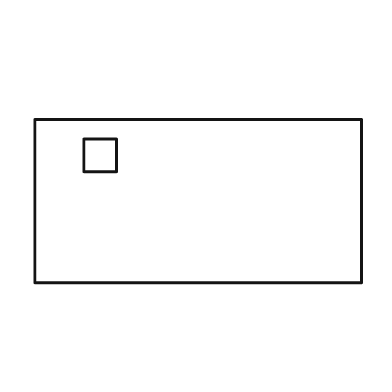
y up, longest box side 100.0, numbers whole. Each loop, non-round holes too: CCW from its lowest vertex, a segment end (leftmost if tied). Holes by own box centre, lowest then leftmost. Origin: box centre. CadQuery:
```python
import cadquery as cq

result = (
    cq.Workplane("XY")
    .moveTo(-50.0, -25.0)
    .lineTo(50.0, -25.0)
    .lineTo(50.0, 25.0)
    .lineTo(-50.0, 25.0)
    .close()
    .moveTo(-35.0, 9.0)
    .lineTo(-25.0, 9.0)
    .lineTo(-25.0, 19.0)
    .lineTo(-35.0, 19.0)
    .close()
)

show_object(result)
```